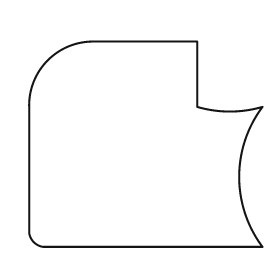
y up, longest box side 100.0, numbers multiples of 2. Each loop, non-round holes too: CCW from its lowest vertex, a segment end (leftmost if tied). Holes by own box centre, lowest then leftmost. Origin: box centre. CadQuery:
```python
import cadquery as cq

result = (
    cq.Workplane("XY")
    .moveTo(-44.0, -44.0)
    .lineTo(50.0, -44.0)
    .threePointArc((40.0, -14.0), (50.0, 16.0))
    .threePointArc((36.0, 14.0), (22.0, 16.0))
    .lineTo(22.0, 44.0)
    .lineTo(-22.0, 44.0)
    .threePointArc((-42.0, 36.0), (-50.0, 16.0))
    .lineTo(-50.0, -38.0)
    .threePointArc((-48.0, -42.0), (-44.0, -44.0))
    .close()
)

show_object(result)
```